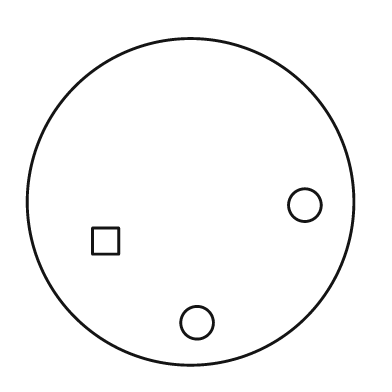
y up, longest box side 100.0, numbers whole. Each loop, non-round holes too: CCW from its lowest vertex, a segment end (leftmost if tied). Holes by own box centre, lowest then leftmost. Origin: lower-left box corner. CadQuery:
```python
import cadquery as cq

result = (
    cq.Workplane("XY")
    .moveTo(50.0, 50.0)
    .circle(50.0)
    .moveTo(52.0, 13.0)
    .circle(5.0)
    .moveTo(20.0, 34.0)
    .lineTo(28.0, 34.0)
    .lineTo(28.0, 42.0)
    .lineTo(20.0, 42.0)
    .close()
    .moveTo(85.0, 49.0)
    .circle(5.0)
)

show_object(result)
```